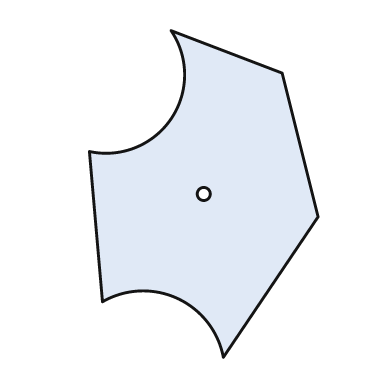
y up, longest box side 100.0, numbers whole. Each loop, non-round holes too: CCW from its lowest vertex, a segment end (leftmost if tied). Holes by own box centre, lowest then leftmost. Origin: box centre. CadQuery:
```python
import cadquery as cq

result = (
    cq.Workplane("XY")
    .moveTo(6.0, -50.0)
    .lineTo(35.0, -7.0)
    .lineTo(24.0, 37.0)
    .lineTo(-10.0, 50.0)
    .threePointArc((-10.0, 23.0), (-35.0, 13.0))
    .lineTo(-31.0, -33.0)
    .threePointArc((-8.0, -32.0), (6.0, -50.0))
    .close()
    .moveTo(0.0, 0.0)
    .circle(2.0)
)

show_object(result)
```